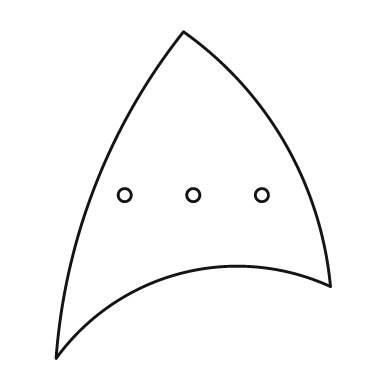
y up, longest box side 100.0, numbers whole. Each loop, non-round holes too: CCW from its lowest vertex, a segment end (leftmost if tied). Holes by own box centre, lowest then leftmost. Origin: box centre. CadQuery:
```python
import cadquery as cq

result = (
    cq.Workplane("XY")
    .moveTo(-42.0, -50.0)
    .threePointArc((-4.0, -24.0), (42.0, -28.0))
    .threePointArc((28.0, 16.0), (-3.0, 50.0))
    .threePointArc((-30.0, 3.0), (-42.0, -50.0))
    .close()
    .moveTo(-21.0, 0.0)
    .circle(2.0)
    .moveTo(0.0, 0.0)
    .circle(2.0)
    .moveTo(21.0, 0.0)
    .circle(2.0)
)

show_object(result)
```